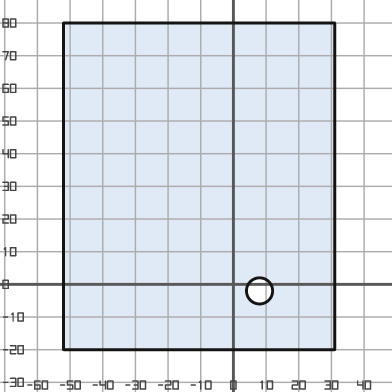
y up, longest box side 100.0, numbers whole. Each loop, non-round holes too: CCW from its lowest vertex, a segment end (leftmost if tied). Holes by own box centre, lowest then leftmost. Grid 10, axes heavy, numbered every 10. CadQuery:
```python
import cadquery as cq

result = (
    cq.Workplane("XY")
    .moveTo(-52.0, -20.0)
    .lineTo(31.0, -20.0)
    .lineTo(31.0, 80.0)
    .lineTo(-52.0, 80.0)
    .close()
    .moveTo(8.0, -2.0)
    .circle(4.0)
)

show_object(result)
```